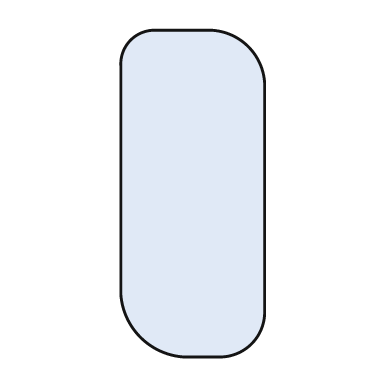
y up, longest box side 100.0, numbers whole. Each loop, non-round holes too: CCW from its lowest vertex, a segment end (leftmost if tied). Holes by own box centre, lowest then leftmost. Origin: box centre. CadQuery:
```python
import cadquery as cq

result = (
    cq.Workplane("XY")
    .moveTo(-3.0, -50.0)
    .lineTo(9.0, -50.0)
    .threePointArc((18.0, -46.0), (22.0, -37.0))
    .lineTo(22.0, 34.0)
    .threePointArc((17.0, 45.0), (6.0, 50.0))
    .lineTo(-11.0, 50.0)
    .threePointArc((-19.0, 47.0), (-22.0, 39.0))
    .lineTo(-22.0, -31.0)
    .threePointArc((-16.0, -44.0), (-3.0, -50.0))
    .close()
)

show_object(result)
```